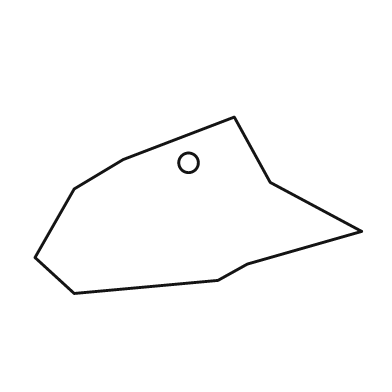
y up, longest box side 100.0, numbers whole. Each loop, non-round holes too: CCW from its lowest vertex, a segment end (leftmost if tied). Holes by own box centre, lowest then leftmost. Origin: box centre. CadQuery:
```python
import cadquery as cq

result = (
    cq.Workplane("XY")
    .moveTo(-38.0, -27.0)
    .lineTo(6.0, -23.0)
    .lineTo(15.0, -18.0)
    .lineTo(50.0, -8.0)
    .lineTo(22.0, 7.0)
    .lineTo(11.0, 27.0)
    .lineTo(-23.0, 14.0)
    .lineTo(-38.0, 5.0)
    .lineTo(-50.0, -16.0)
    .close()
    .moveTo(-3.0, 13.0)
    .circle(3.0)
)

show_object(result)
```